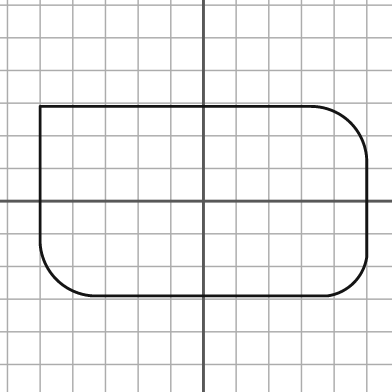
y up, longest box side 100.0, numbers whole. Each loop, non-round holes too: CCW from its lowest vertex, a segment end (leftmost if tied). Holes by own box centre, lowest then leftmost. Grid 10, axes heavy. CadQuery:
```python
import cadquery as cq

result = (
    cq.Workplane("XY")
    .moveTo(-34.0, -29.0)
    .lineTo(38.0, -29.0)
    .threePointArc((46.0, -25.0), (50.0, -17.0))
    .lineTo(50.0, 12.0)
    .threePointArc((45.0, 24.0), (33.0, 29.0))
    .lineTo(-50.0, 29.0)
    .lineTo(-50.0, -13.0)
    .threePointArc((-45.0, -24.0), (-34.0, -29.0))
    .close()
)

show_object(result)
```